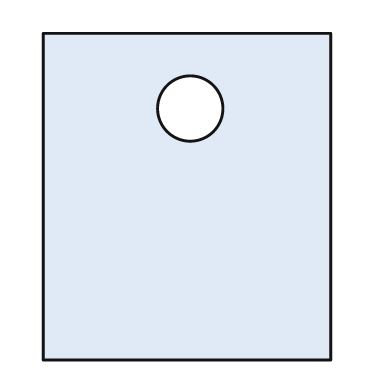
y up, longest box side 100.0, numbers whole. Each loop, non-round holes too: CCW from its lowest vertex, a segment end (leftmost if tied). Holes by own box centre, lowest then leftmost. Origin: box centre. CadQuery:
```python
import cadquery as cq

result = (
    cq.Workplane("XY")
    .moveTo(-44.0, -50.0)
    .lineTo(44.0, -50.0)
    .lineTo(44.0, 50.0)
    .lineTo(-44.0, 50.0)
    .close()
    .moveTo(1.0, 27.0)
    .circle(10.0)
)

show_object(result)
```